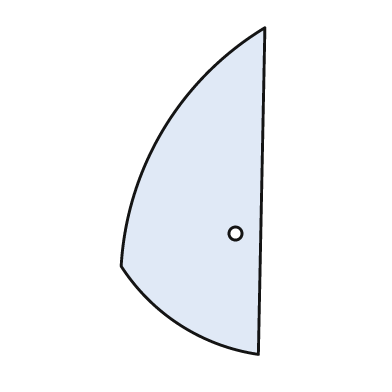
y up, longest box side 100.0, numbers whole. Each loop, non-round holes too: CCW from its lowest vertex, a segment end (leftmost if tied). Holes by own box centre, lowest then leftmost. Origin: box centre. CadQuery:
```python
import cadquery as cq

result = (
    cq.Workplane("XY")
    .moveTo(20.0, -50.0)
    .lineTo(22.0, 50.0)
    .threePointArc((-9.0, 19.0), (-22.0, -23.0))
    .threePointArc((-4.0, -41.0), (20.0, -50.0))
    .close()
    .moveTo(13.0, -13.0)
    .circle(2.0)
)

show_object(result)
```